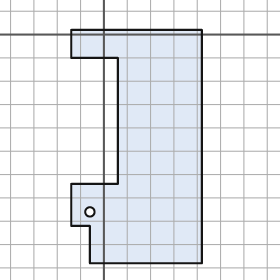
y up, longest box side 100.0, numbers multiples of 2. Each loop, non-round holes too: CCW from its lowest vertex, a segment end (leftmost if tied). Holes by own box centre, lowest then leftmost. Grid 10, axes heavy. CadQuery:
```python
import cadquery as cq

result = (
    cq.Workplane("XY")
    .moveTo(-6.0, -98.0)
    .lineTo(42.0, -98.0)
    .lineTo(42.0, 2.0)
    .lineTo(-14.0, 2.0)
    .lineTo(-14.0, -10.0)
    .lineTo(6.0, -10.0)
    .lineTo(6.0, -64.0)
    .lineTo(-14.0, -64.0)
    .lineTo(-14.0, -82.0)
    .lineTo(-6.0, -82.0)
    .close()
    .moveTo(-6.0, -76.0)
    .circle(2.0)
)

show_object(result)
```